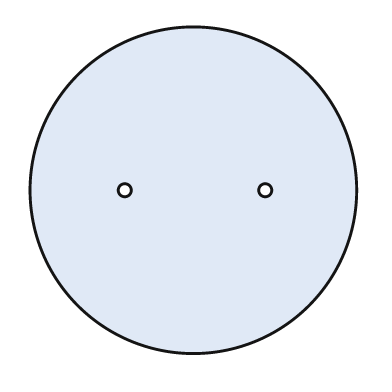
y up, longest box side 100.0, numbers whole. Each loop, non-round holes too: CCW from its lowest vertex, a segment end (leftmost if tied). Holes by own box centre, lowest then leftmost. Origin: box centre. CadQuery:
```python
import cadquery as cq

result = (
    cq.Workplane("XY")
    .moveTo(0.0, 0.0)
    .circle(50.0)
    .moveTo(-21.0, 0.0)
    .circle(2.0)
    .moveTo(22.0, 0.0)
    .circle(2.0)
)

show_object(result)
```